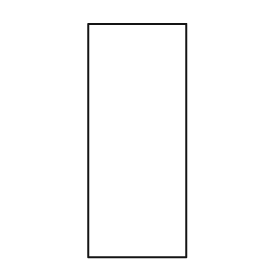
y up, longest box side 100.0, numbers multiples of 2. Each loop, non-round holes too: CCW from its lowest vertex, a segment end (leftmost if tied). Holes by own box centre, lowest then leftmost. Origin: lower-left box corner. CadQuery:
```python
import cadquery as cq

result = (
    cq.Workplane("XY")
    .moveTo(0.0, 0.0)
    .lineTo(42.0, 0.0)
    .lineTo(42.0, 100.0)
    .lineTo(0.0, 100.0)
    .close()
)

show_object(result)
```